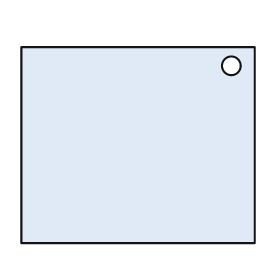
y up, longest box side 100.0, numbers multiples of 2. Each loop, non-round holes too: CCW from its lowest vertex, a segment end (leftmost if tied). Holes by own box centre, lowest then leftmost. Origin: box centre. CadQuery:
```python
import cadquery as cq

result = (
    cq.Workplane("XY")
    .moveTo(-50.0, -42.0)
    .lineTo(50.0, -42.0)
    .lineTo(50.0, 42.0)
    .lineTo(-50.0, 42.0)
    .close()
    .moveTo(40.0, 34.0)
    .circle(4.0)
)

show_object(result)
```